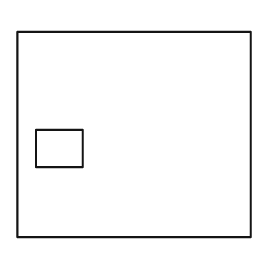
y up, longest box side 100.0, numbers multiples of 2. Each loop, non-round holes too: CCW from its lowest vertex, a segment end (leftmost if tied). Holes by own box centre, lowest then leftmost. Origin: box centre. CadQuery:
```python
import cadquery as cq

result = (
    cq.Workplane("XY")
    .moveTo(-50.0, -44.0)
    .lineTo(50.0, -44.0)
    .lineTo(50.0, 44.0)
    .lineTo(-50.0, 44.0)
    .close()
    .moveTo(-42.0, -14.0)
    .lineTo(-22.0, -14.0)
    .lineTo(-22.0, 2.0)
    .lineTo(-42.0, 2.0)
    .close()
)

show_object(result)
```